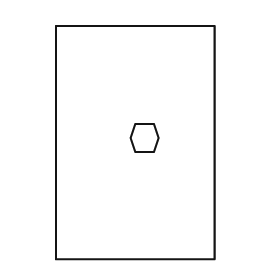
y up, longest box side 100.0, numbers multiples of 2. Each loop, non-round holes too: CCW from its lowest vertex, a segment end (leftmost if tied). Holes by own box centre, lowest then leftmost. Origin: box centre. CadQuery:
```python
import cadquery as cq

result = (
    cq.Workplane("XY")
    .moveTo(-34.0, -50.0)
    .lineTo(34.0, -50.0)
    .lineTo(34.0, 50.0)
    .lineTo(-34.0, 50.0)
    .close()
    .moveTo(0.0, -4.0)
    .lineTo(8.0, -4.0)
    .lineTo(10.0, 2.0)
    .lineTo(8.0, 8.0)
    .lineTo(0.0, 8.0)
    .lineTo(-2.0, 2.0)
    .close()
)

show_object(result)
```